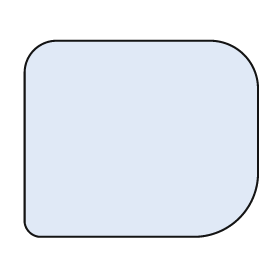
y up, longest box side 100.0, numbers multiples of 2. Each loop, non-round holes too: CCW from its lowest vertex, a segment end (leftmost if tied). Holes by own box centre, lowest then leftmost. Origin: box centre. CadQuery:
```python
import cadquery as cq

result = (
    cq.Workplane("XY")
    .moveTo(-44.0, -42.0)
    .lineTo(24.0, -42.0)
    .threePointArc((42.0, -34.0), (50.0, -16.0))
    .lineTo(50.0, 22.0)
    .threePointArc((44.0, 36.0), (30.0, 42.0))
    .lineTo(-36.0, 42.0)
    .threePointArc((-46.0, 38.0), (-50.0, 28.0))
    .lineTo(-50.0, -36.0)
    .threePointArc((-48.0, -40.0), (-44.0, -42.0))
    .close()
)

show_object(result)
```